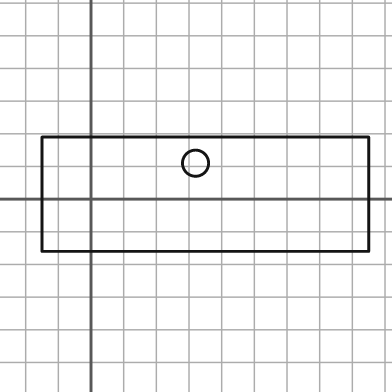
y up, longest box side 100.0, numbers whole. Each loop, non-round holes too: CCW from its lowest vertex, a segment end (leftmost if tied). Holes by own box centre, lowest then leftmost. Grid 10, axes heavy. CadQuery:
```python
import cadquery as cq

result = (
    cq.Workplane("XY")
    .moveTo(-15.0, -16.0)
    .lineTo(85.0, -16.0)
    .lineTo(85.0, 19.0)
    .lineTo(-15.0, 19.0)
    .close()
    .moveTo(32.0, 11.0)
    .circle(4.0)
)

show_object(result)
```